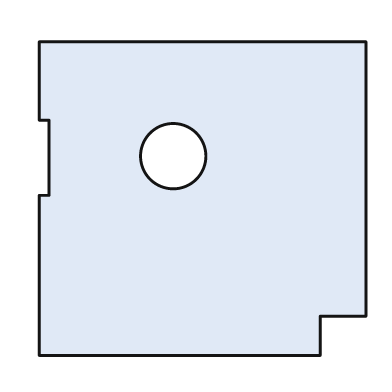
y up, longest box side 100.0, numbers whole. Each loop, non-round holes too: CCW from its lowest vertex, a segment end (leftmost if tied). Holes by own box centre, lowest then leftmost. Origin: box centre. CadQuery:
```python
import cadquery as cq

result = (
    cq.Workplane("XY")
    .moveTo(-50.0, -48.0)
    .lineTo(36.0, -48.0)
    .lineTo(36.0, -36.0)
    .lineTo(50.0, -36.0)
    .lineTo(50.0, 48.0)
    .lineTo(-50.0, 48.0)
    .lineTo(-50.0, 24.0)
    .lineTo(-47.0, 24.0)
    .lineTo(-47.0, 1.0)
    .lineTo(-50.0, 1.0)
    .close()
    .moveTo(-9.0, 13.0)
    .circle(10.0)
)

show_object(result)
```